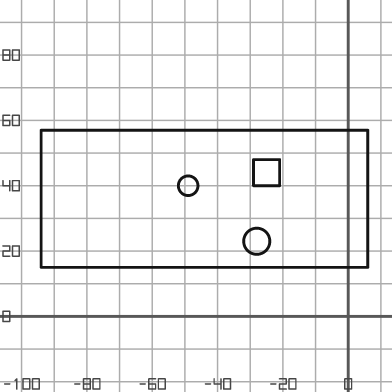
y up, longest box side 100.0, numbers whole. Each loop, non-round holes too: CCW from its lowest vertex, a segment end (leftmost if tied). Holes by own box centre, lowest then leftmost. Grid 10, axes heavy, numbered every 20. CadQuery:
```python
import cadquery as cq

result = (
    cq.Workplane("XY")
    .moveTo(-94.0, 15.0)
    .lineTo(6.0, 15.0)
    .lineTo(6.0, 57.0)
    .lineTo(-94.0, 57.0)
    .close()
    .moveTo(-28.0, 23.0)
    .circle(4.0)
    .moveTo(-49.0, 40.0)
    .circle(3.0)
    .moveTo(-29.0, 40.0)
    .lineTo(-21.0, 40.0)
    .lineTo(-21.0, 48.0)
    .lineTo(-29.0, 48.0)
    .close()
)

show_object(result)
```